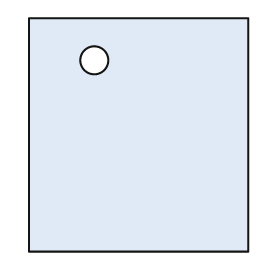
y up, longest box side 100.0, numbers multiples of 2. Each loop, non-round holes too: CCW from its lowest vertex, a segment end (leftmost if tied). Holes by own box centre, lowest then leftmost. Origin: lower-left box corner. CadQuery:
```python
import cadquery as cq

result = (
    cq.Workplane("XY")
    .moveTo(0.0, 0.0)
    .lineTo(94.0, 0.0)
    .lineTo(94.0, 100.0)
    .lineTo(0.0, 100.0)
    .close()
    .moveTo(28.0, 82.0)
    .circle(6.0)
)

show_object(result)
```